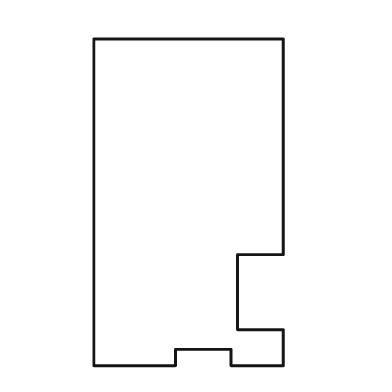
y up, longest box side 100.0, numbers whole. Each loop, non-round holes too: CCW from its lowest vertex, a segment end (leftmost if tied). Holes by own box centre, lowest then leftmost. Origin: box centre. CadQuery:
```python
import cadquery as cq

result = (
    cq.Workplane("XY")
    .moveTo(-29.0, -50.0)
    .lineTo(-4.0, -50.0)
    .lineTo(-4.0, -45.0)
    .lineTo(13.0, -45.0)
    .lineTo(13.0, -50.0)
    .lineTo(29.0, -50.0)
    .lineTo(29.0, -39.0)
    .lineTo(15.0, -39.0)
    .lineTo(15.0, -16.0)
    .lineTo(29.0, -16.0)
    .lineTo(29.0, 50.0)
    .lineTo(-29.0, 50.0)
    .close()
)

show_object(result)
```